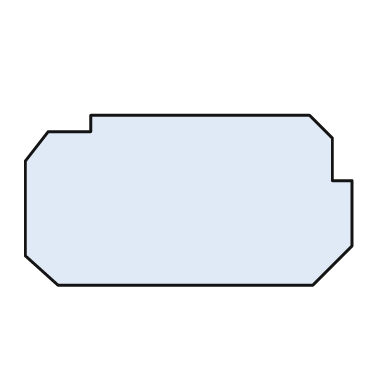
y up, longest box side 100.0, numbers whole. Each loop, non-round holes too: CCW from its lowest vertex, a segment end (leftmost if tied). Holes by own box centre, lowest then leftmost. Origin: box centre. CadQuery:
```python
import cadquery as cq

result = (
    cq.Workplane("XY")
    .moveTo(-40.0, -26.0)
    .lineTo(38.0, -26.0)
    .lineTo(50.0, -14.0)
    .lineTo(50.0, 6.0)
    .lineTo(44.0, 6.0)
    .lineTo(44.0, 19.0)
    .lineTo(37.0, 26.0)
    .lineTo(-30.0, 26.0)
    .lineTo(-30.0, 21.0)
    .lineTo(-43.0, 21.0)
    .lineTo(-50.0, 12.0)
    .lineTo(-50.0, -17.0)
    .close()
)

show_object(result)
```